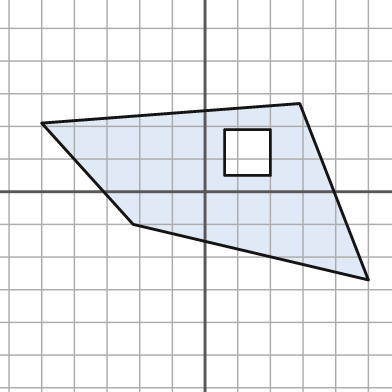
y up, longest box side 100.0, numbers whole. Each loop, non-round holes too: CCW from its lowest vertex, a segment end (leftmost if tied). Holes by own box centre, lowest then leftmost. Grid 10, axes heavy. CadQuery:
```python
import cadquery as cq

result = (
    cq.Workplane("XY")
    .moveTo(50.0, -27.0)
    .lineTo(29.0, 27.0)
    .lineTo(-50.0, 21.0)
    .lineTo(-22.0, -10.0)
    .close()
    .moveTo(6.0, 5.0)
    .lineTo(20.0, 5.0)
    .lineTo(20.0, 19.0)
    .lineTo(6.0, 19.0)
    .close()
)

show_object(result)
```